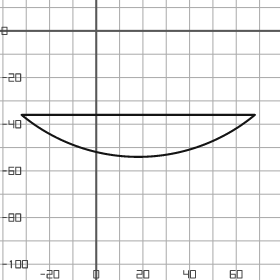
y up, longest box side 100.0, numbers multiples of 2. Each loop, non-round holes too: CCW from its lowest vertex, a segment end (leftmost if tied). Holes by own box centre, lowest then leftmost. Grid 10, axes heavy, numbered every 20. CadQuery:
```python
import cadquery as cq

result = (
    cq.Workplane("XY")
    .moveTo(-32.0, -36.0)
    .threePointArc((18.0, -54.0), (68.0, -36.0))
    .close()
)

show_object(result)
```